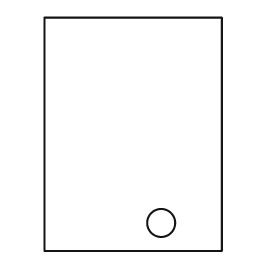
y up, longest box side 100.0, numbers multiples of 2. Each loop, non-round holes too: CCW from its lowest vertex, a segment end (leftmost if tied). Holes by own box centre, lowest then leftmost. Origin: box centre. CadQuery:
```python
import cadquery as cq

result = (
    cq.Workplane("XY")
    .moveTo(-38.0, -50.0)
    .lineTo(38.0, -50.0)
    .lineTo(38.0, 50.0)
    .lineTo(-38.0, 50.0)
    .close()
    .moveTo(12.0, -38.0)
    .circle(6.0)
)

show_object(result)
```